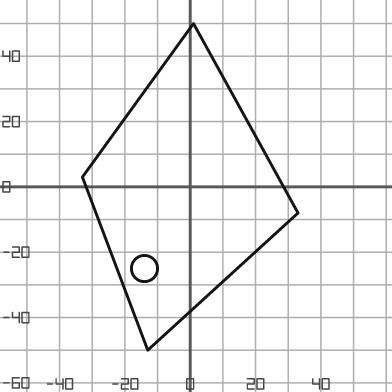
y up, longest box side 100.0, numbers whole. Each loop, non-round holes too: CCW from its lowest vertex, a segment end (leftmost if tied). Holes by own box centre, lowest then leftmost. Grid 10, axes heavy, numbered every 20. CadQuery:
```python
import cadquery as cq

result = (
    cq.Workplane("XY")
    .moveTo(-13.0, -50.0)
    .lineTo(33.0, -8.0)
    .lineTo(1.0, 50.0)
    .lineTo(-33.0, 3.0)
    .close()
    .moveTo(-14.0, -25.0)
    .circle(4.0)
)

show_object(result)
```